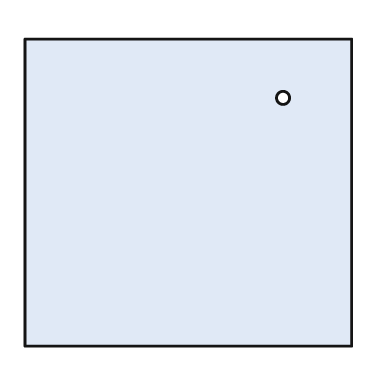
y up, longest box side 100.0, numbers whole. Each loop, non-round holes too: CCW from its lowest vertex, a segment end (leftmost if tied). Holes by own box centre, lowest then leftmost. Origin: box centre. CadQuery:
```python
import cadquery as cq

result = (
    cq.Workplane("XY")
    .moveTo(-50.0, -47.0)
    .lineTo(50.0, -47.0)
    .lineTo(50.0, 47.0)
    .lineTo(-50.0, 47.0)
    .close()
    .moveTo(29.0, 29.0)
    .circle(2.0)
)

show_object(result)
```